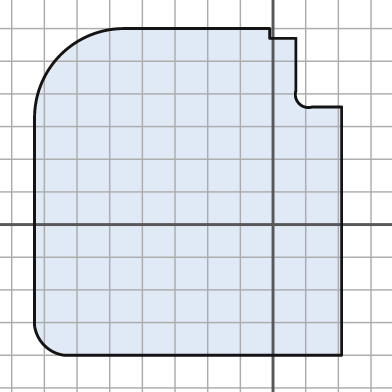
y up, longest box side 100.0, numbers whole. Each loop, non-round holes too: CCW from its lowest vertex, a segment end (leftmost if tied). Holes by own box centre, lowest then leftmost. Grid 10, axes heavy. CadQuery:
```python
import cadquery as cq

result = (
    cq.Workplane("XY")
    .moveTo(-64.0, -40.0)
    .lineTo(21.0, -40.0)
    .lineTo(21.0, 36.0)
    .lineTo(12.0, 36.0)
    .threePointArc((8.0, 37.0), (7.0, 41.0))
    .lineTo(7.0, 57.0)
    .lineTo(-1.0, 57.0)
    .lineTo(-1.0, 60.0)
    .lineTo(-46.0, 60.0)
    .threePointArc((-65.0, 52.0), (-73.0, 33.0))
    .lineTo(-73.0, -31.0)
    .threePointArc((-70.0, -37.0), (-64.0, -40.0))
    .close()
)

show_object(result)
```